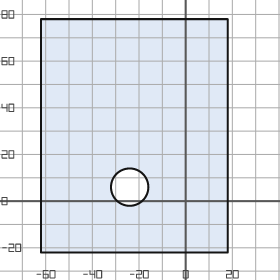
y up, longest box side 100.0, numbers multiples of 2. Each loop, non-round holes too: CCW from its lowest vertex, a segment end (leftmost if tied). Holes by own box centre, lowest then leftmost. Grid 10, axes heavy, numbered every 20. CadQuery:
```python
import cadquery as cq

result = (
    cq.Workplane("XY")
    .moveTo(-62.0, -22.0)
    .lineTo(18.0, -22.0)
    .lineTo(18.0, 78.0)
    .lineTo(-62.0, 78.0)
    .close()
    .moveTo(-24.0, 6.0)
    .circle(8.0)
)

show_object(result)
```